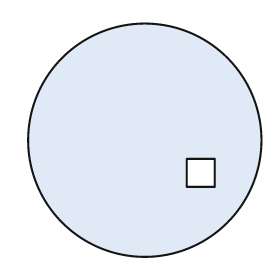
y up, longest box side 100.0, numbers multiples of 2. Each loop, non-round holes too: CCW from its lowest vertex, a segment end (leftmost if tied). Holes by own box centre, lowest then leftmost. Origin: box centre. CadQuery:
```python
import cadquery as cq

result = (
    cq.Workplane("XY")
    .moveTo(0.0, 0.0)
    .circle(50.0)
    .moveTo(18.0, -20.0)
    .lineTo(30.0, -20.0)
    .lineTo(30.0, -8.0)
    .lineTo(18.0, -8.0)
    .close()
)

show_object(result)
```